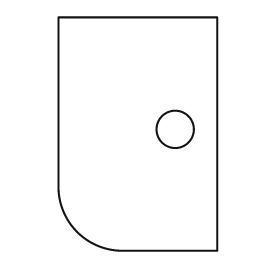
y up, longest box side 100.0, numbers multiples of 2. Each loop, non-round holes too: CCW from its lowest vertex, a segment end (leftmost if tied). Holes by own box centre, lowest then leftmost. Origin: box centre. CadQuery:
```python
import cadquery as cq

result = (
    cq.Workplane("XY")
    .moveTo(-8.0, -50.0)
    .lineTo(34.0, -50.0)
    .lineTo(34.0, 50.0)
    .lineTo(-34.0, 50.0)
    .lineTo(-34.0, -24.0)
    .threePointArc((-26.0, -42.0), (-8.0, -50.0))
    .close()
    .moveTo(16.0, 2.0)
    .circle(8.0)
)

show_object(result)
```